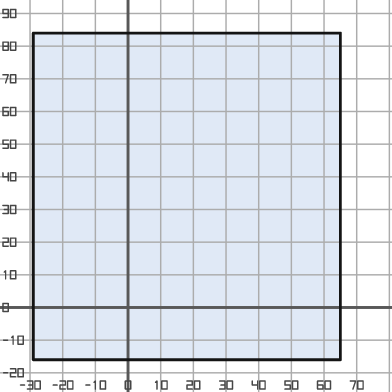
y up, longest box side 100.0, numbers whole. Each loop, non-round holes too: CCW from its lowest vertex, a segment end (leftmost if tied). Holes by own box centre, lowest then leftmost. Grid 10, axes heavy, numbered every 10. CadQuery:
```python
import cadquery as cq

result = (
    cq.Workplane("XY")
    .moveTo(-29.0, -16.0)
    .lineTo(65.0, -16.0)
    .lineTo(65.0, 84.0)
    .lineTo(-29.0, 84.0)
    .close()
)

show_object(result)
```